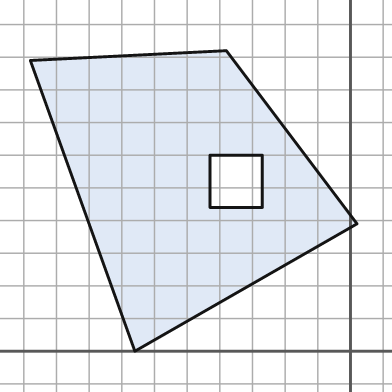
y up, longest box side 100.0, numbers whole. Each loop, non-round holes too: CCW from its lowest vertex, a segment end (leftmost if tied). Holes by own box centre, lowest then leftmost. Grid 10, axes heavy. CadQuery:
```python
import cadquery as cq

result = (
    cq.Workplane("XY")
    .moveTo(-66.0, 0.0)
    .lineTo(2.0, 39.0)
    .lineTo(-38.0, 92.0)
    .lineTo(-98.0, 89.0)
    .close()
    .moveTo(-43.0, 44.0)
    .lineTo(-27.0, 44.0)
    .lineTo(-27.0, 60.0)
    .lineTo(-43.0, 60.0)
    .close()
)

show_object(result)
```